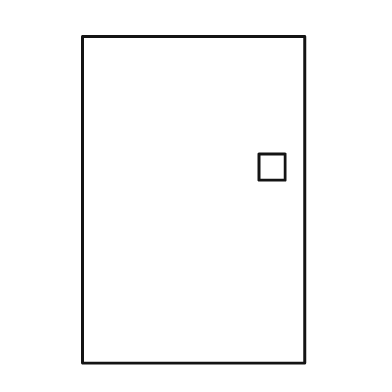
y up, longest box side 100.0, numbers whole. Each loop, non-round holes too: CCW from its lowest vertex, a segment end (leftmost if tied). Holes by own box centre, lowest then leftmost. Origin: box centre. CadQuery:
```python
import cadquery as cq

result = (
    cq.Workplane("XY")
    .moveTo(-34.0, -50.0)
    .lineTo(34.0, -50.0)
    .lineTo(34.0, 50.0)
    .lineTo(-34.0, 50.0)
    .close()
    .moveTo(20.0, 6.0)
    .lineTo(28.0, 6.0)
    .lineTo(28.0, 14.0)
    .lineTo(20.0, 14.0)
    .close()
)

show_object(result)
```